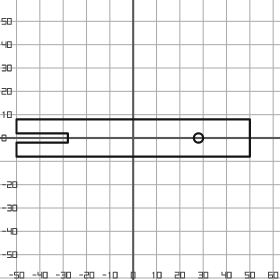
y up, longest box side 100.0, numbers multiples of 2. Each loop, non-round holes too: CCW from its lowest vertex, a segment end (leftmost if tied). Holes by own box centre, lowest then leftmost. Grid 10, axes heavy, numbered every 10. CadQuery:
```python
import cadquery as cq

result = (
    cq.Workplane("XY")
    .moveTo(-50.0, -8.0)
    .lineTo(50.0, -8.0)
    .lineTo(50.0, 8.0)
    .lineTo(-50.0, 8.0)
    .lineTo(-50.0, 2.0)
    .lineTo(-28.0, 2.0)
    .lineTo(-28.0, -2.0)
    .lineTo(-50.0, -2.0)
    .close()
    .moveTo(28.0, 0.0)
    .circle(2.0)
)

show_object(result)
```